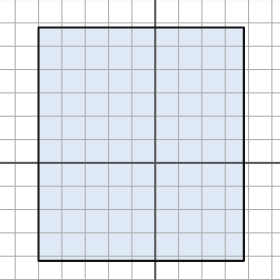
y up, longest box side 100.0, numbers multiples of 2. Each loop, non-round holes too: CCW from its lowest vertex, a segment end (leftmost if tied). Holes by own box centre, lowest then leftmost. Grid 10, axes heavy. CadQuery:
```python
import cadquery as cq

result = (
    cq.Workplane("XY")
    .moveTo(-50.0, -42.0)
    .lineTo(38.0, -42.0)
    .lineTo(38.0, 58.0)
    .lineTo(-50.0, 58.0)
    .close()
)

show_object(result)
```